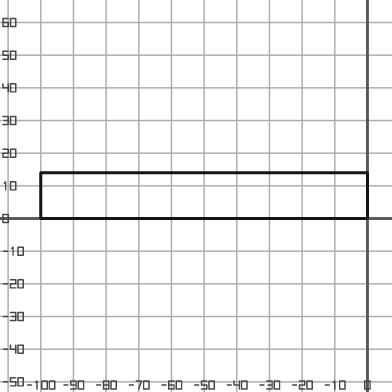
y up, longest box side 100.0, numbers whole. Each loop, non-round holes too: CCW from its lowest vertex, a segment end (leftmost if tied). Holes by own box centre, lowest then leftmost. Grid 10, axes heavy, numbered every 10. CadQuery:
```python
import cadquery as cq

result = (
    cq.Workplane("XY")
    .moveTo(-100.0, 0.0)
    .lineTo(0.0, 0.0)
    .lineTo(0.0, 14.0)
    .lineTo(-100.0, 14.0)
    .close()
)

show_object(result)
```